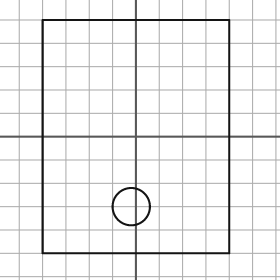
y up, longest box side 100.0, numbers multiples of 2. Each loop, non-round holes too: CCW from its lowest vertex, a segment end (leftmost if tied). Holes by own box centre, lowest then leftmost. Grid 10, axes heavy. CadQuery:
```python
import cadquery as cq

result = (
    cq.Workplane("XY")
    .moveTo(-40.0, -50.0)
    .lineTo(40.0, -50.0)
    .lineTo(40.0, 50.0)
    .lineTo(-40.0, 50.0)
    .close()
    .moveTo(-2.0, -30.0)
    .circle(8.0)
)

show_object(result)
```